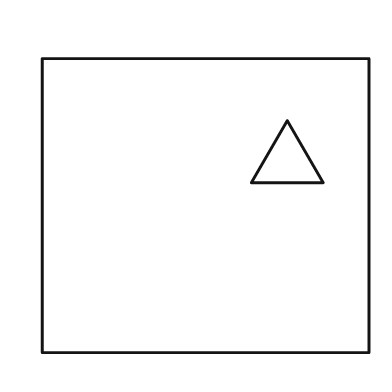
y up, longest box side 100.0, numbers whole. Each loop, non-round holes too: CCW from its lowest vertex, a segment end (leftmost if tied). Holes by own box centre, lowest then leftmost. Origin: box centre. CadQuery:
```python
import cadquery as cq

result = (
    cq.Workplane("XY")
    .moveTo(-50.0, -45.0)
    .lineTo(50.0, -45.0)
    .lineTo(50.0, 45.0)
    .lineTo(-50.0, 45.0)
    .close()
    .moveTo(14.0, 7.0)
    .lineTo(36.0, 7.0)
    .lineTo(25.0, 26.0)
    .close()
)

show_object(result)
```